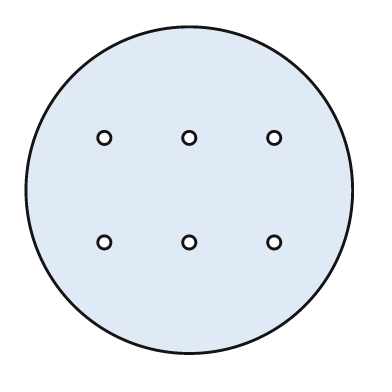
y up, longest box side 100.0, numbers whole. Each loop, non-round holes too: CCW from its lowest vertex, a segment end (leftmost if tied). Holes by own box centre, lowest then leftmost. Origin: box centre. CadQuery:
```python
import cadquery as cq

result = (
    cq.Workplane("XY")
    .moveTo(0.0, 0.0)
    .circle(50.0)
    .moveTo(-26.0, -16.0)
    .circle(2.0)
    .moveTo(0.0, -16.0)
    .circle(2.0)
    .moveTo(26.0, -16.0)
    .circle(2.0)
    .moveTo(-26.0, 16.0)
    .circle(2.0)
    .moveTo(0.0, 16.0)
    .circle(2.0)
    .moveTo(26.0, 16.0)
    .circle(2.0)
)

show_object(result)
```